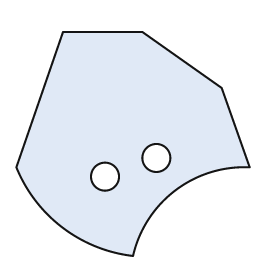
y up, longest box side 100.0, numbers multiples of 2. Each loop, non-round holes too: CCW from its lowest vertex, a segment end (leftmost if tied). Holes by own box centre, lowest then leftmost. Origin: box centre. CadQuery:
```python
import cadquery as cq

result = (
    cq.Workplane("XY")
    .moveTo(0.0, -48.0)
    .threePointArc((18.0, -20.0), (50.0, -10.0))
    .lineTo(38.0, 24.0)
    .lineTo(4.0, 48.0)
    .lineTo(-30.0, 48.0)
    .lineTo(-50.0, -10.0)
    .threePointArc((-30.0, -36.0), (0.0, -48.0))
    .close()
    .moveTo(-12.0, -14.0)
    .circle(6.0)
    .moveTo(10.0, -6.0)
    .circle(6.0)
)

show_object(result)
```